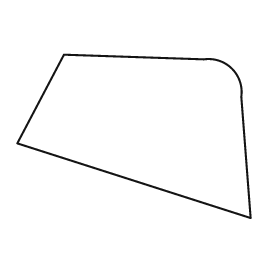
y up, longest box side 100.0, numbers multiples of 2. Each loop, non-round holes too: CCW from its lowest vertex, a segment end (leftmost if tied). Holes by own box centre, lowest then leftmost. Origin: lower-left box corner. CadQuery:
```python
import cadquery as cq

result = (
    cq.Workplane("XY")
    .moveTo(100.0, 0.0)
    .lineTo(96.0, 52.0)
    .threePointArc((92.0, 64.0), (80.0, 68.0))
    .lineTo(20.0, 70.0)
    .lineTo(0.0, 32.0)
    .close()
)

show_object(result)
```